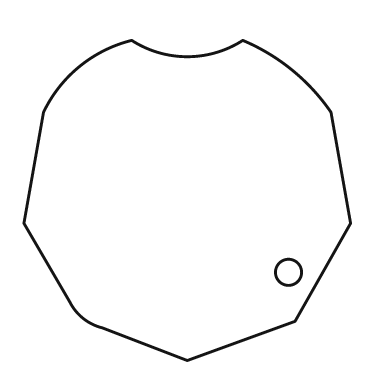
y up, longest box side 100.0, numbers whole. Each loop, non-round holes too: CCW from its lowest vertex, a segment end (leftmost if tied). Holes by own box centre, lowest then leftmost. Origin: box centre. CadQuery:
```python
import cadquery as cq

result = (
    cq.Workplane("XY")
    .moveTo(0.0, -49.0)
    .lineTo(33.0, -37.0)
    .lineTo(50.0, -7.0)
    .lineTo(44.0, 27.0)
    .threePointArc((32.0, 40.0), (17.0, 49.0))
    .threePointArc((0.0, 44.0), (-17.0, 49.0))
    .threePointArc((-33.0, 41.0), (-44.0, 27.0))
    .lineTo(-50.0, -7.0)
    .lineTo(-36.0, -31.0)
    .threePointArc((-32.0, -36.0), (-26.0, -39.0))
    .close()
    .moveTo(31.0, -22.0)
    .circle(4.0)
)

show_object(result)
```